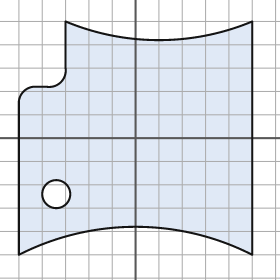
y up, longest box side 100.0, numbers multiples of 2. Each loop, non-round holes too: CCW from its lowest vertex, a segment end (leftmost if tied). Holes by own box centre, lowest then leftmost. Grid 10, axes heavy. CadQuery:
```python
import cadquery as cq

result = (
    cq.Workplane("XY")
    .moveTo(-50.0, -50.0)
    .threePointArc((0.0, -38.0), (50.0, -50.0))
    .lineTo(50.0, 50.0)
    .threePointArc((10.0, 42.0), (-30.0, 50.0))
    .lineTo(-30.0, 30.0)
    .threePointArc((-32.0, 24.0), (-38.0, 22.0))
    .lineTo(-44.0, 22.0)
    .threePointArc((-48.0, 20.0), (-50.0, 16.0))
    .close()
    .moveTo(-34.0, -24.0)
    .circle(6.0)
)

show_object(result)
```